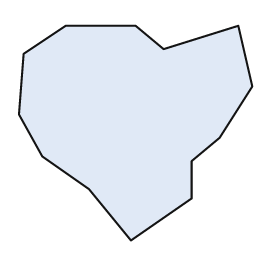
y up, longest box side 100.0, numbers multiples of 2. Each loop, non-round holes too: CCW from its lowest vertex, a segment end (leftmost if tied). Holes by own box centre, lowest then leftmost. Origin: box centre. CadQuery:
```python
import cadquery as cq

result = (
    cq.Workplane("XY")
    .moveTo(-2.0, -46.0)
    .lineTo(24.0, -28.0)
    .lineTo(24.0, -12.0)
    .lineTo(36.0, -2.0)
    .lineTo(50.0, 20.0)
    .lineTo(44.0, 46.0)
    .lineTo(12.0, 36.0)
    .lineTo(0.0, 46.0)
    .lineTo(-30.0, 46.0)
    .lineTo(-48.0, 34.0)
    .lineTo(-50.0, 8.0)
    .lineTo(-40.0, -10.0)
    .lineTo(-20.0, -24.0)
    .close()
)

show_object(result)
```